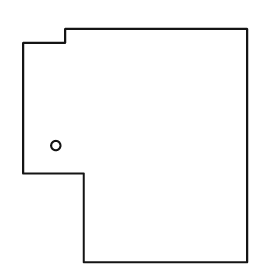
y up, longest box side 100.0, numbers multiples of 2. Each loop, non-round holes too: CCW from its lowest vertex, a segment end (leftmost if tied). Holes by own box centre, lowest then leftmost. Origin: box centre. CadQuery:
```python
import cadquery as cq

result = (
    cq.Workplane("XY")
    .moveTo(-22.0, -50.0)
    .lineTo(48.0, -50.0)
    .lineTo(48.0, 50.0)
    .lineTo(-30.0, 50.0)
    .lineTo(-30.0, 44.0)
    .lineTo(-48.0, 44.0)
    .lineTo(-48.0, -12.0)
    .lineTo(-22.0, -12.0)
    .close()
    .moveTo(-34.0, 0.0)
    .circle(2.0)
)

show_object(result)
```